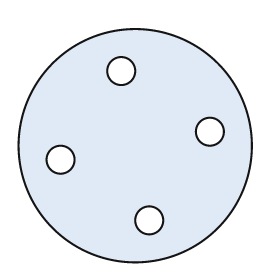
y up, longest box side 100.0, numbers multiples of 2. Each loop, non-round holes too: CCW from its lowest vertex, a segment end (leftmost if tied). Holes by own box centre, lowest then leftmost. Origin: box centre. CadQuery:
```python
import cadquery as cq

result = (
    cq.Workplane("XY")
    .moveTo(0.0, 0.0)
    .circle(50.0)
    .moveTo(6.0, -32.0)
    .circle(6.0)
    .moveTo(-32.0, -6.0)
    .circle(6.0)
    .moveTo(32.0, 6.0)
    .circle(6.0)
    .moveTo(-6.0, 32.0)
    .circle(6.0)
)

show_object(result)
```